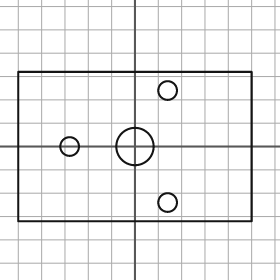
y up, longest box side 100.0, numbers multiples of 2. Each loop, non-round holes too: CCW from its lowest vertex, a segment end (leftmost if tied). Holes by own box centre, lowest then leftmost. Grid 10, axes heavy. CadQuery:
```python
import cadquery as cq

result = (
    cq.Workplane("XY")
    .moveTo(-50.0, -32.0)
    .lineTo(50.0, -32.0)
    .lineTo(50.0, 32.0)
    .lineTo(-50.0, 32.0)
    .close()
    .moveTo(14.0, -24.0)
    .circle(4.0)
    .moveTo(-28.0, 0.0)
    .circle(4.0)
    .moveTo(0.0, 0.0)
    .circle(8.0)
    .moveTo(14.0, 24.0)
    .circle(4.0)
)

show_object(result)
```